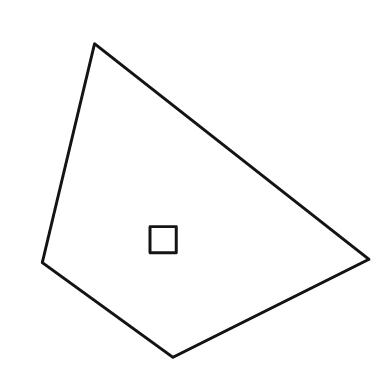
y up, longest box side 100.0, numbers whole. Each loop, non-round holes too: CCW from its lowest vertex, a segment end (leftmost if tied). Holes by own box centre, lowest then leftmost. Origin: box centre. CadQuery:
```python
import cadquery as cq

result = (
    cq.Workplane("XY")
    .moveTo(-10.0, -48.0)
    .lineTo(50.0, -18.0)
    .lineTo(-34.0, 48.0)
    .lineTo(-50.0, -19.0)
    .close()
    .moveTo(-17.0, -16.0)
    .lineTo(-9.0, -16.0)
    .lineTo(-9.0, -8.0)
    .lineTo(-17.0, -8.0)
    .close()
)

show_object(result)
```